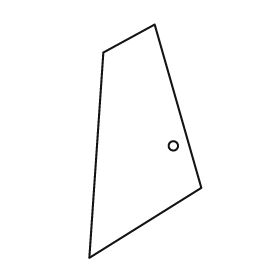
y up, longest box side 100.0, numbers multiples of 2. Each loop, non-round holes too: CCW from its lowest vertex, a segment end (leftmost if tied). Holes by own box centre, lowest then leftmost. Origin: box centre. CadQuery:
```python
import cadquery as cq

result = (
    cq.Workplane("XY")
    .moveTo(-24.0, -50.0)
    .lineTo(24.0, -20.0)
    .lineTo(4.0, 50.0)
    .lineTo(-18.0, 38.0)
    .close()
    .moveTo(12.0, -2.0)
    .circle(2.0)
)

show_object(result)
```